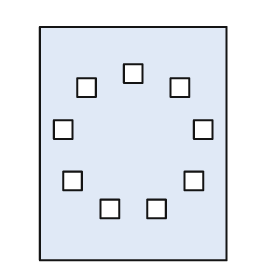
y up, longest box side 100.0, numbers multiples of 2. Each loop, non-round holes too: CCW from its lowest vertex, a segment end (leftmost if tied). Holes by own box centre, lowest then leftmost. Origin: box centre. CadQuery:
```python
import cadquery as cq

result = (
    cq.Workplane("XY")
    .moveTo(-40.0, -50.0)
    .lineTo(40.0, -50.0)
    .lineTo(40.0, 50.0)
    .lineTo(-40.0, 50.0)
    .close()
    .moveTo(-14.0, -32.0)
    .lineTo(-6.0, -32.0)
    .lineTo(-6.0, -24.0)
    .lineTo(-14.0, -24.0)
    .close()
    .moveTo(6.0, -32.0)
    .lineTo(14.0, -32.0)
    .lineTo(14.0, -24.0)
    .lineTo(6.0, -24.0)
    .close()
    .moveTo(-30.0, -20.0)
    .lineTo(-22.0, -20.0)
    .lineTo(-22.0, -12.0)
    .lineTo(-30.0, -12.0)
    .close()
    .moveTo(22.0, -20.0)
    .lineTo(30.0, -20.0)
    .lineTo(30.0, -12.0)
    .lineTo(22.0, -12.0)
    .close()
    .moveTo(-34.0, 2.0)
    .lineTo(-26.0, 2.0)
    .lineTo(-26.0, 10.0)
    .lineTo(-34.0, 10.0)
    .close()
    .moveTo(26.0, 2.0)
    .lineTo(34.0, 2.0)
    .lineTo(34.0, 10.0)
    .lineTo(26.0, 10.0)
    .close()
    .moveTo(-24.0, 20.0)
    .lineTo(-16.0, 20.0)
    .lineTo(-16.0, 28.0)
    .lineTo(-24.0, 28.0)
    .close()
    .moveTo(16.0, 20.0)
    .lineTo(24.0, 20.0)
    .lineTo(24.0, 28.0)
    .lineTo(16.0, 28.0)
    .close()
    .moveTo(-4.0, 26.0)
    .lineTo(4.0, 26.0)
    .lineTo(4.0, 34.0)
    .lineTo(-4.0, 34.0)
    .close()
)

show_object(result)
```